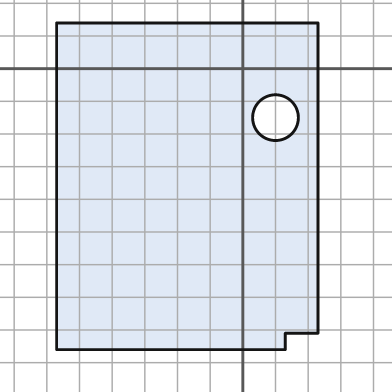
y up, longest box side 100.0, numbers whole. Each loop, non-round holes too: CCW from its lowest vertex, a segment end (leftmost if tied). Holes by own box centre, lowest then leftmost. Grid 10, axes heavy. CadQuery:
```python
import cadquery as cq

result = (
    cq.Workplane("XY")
    .moveTo(-57.0, -86.0)
    .lineTo(13.0, -86.0)
    .lineTo(13.0, -81.0)
    .lineTo(23.0, -81.0)
    .lineTo(23.0, 14.0)
    .lineTo(-57.0, 14.0)
    .close()
    .moveTo(10.0, -15.0)
    .circle(7.0)
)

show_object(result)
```